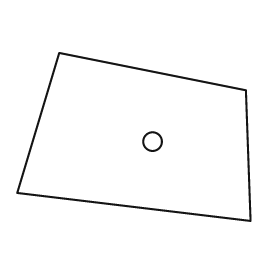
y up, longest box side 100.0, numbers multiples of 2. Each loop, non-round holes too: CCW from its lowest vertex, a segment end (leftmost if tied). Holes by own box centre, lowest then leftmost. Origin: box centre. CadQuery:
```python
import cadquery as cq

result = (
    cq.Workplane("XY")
    .moveTo(50.0, -36.0)
    .lineTo(48.0, 20.0)
    .lineTo(-32.0, 36.0)
    .lineTo(-50.0, -24.0)
    .close()
    .moveTo(8.0, -2.0)
    .circle(4.0)
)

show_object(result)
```